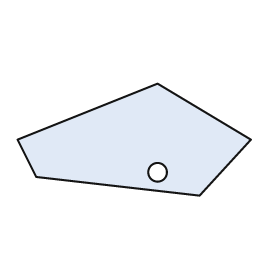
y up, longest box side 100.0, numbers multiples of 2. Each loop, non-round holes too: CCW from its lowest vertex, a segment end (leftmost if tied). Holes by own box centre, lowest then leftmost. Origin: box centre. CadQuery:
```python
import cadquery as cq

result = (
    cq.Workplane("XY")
    .moveTo(28.0, -24.0)
    .lineTo(50.0, 0.0)
    .lineTo(10.0, 24.0)
    .lineTo(-50.0, 0.0)
    .lineTo(-42.0, -16.0)
    .close()
    .moveTo(10.0, -14.0)
    .circle(4.0)
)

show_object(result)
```